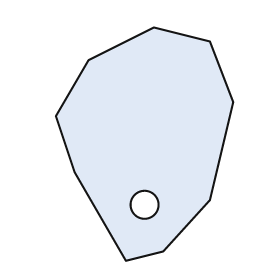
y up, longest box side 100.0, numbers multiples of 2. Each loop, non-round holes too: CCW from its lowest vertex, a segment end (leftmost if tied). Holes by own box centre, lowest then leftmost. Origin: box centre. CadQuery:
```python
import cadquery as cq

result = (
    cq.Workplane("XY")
    .moveTo(-8.0, -50.0)
    .lineTo(8.0, -46.0)
    .lineTo(28.0, -24.0)
    .lineTo(38.0, 18.0)
    .lineTo(28.0, 44.0)
    .lineTo(4.0, 50.0)
    .lineTo(-24.0, 36.0)
    .lineTo(-38.0, 12.0)
    .lineTo(-30.0, -12.0)
    .close()
    .moveTo(0.0, -26.0)
    .circle(6.0)
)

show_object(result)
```